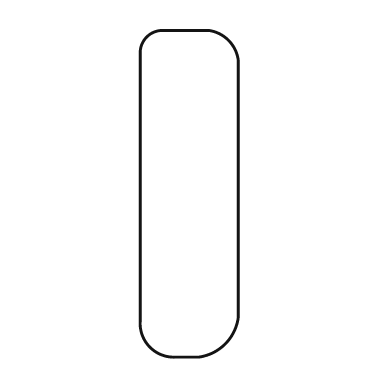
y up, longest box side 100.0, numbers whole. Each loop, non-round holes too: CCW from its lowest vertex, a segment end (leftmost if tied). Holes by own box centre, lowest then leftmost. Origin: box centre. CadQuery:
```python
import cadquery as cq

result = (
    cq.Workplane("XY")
    .moveTo(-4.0, -50.0)
    .lineTo(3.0, -50.0)
    .threePointArc((11.0, -46.0), (15.0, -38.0))
    .lineTo(15.0, 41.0)
    .threePointArc((12.0, 47.0), (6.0, 50.0))
    .lineTo(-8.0, 50.0)
    .threePointArc((-13.0, 48.0), (-15.0, 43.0))
    .lineTo(-15.0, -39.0)
    .threePointArc((-12.0, -47.0), (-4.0, -50.0))
    .close()
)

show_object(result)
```